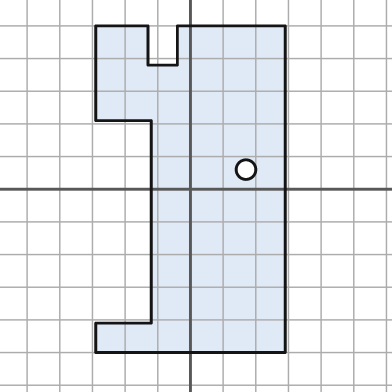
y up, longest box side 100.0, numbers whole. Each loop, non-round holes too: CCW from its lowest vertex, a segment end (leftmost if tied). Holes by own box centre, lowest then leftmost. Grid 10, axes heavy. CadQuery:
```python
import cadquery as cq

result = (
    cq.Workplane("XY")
    .moveTo(-29.0, -50.0)
    .lineTo(29.0, -50.0)
    .lineTo(29.0, 50.0)
    .lineTo(-4.0, 50.0)
    .lineTo(-4.0, 38.0)
    .lineTo(-13.0, 38.0)
    .lineTo(-13.0, 50.0)
    .lineTo(-29.0, 50.0)
    .lineTo(-29.0, 21.0)
    .lineTo(-12.0, 21.0)
    .lineTo(-12.0, -41.0)
    .lineTo(-29.0, -41.0)
    .close()
    .moveTo(17.0, 6.0)
    .circle(3.0)
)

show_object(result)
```